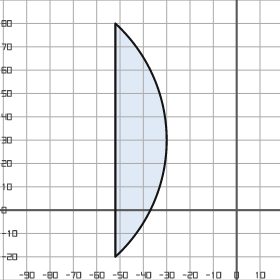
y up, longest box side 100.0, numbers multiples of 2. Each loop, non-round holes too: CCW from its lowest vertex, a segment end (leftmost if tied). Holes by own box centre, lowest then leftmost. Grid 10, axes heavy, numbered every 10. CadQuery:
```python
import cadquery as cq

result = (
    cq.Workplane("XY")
    .moveTo(-52.0, -20.0)
    .threePointArc((-30.0, 30.0), (-52.0, 80.0))
    .close()
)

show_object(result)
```